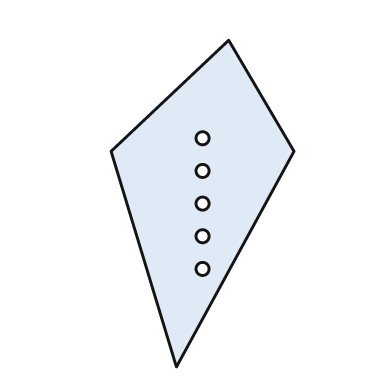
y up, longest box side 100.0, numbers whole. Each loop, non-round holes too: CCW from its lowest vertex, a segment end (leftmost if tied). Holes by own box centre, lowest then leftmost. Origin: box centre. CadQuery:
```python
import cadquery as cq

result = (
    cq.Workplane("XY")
    .moveTo(-8.0, -50.0)
    .lineTo(28.0, 16.0)
    .lineTo(8.0, 50.0)
    .lineTo(-28.0, 16.0)
    .close()
    .moveTo(0.0, -20.0)
    .circle(2.0)
    .moveTo(0.0, -10.0)
    .circle(2.0)
    .moveTo(0.0, 0.0)
    .circle(2.0)
    .moveTo(0.0, 10.0)
    .circle(2.0)
    .moveTo(0.0, 20.0)
    .circle(2.0)
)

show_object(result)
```